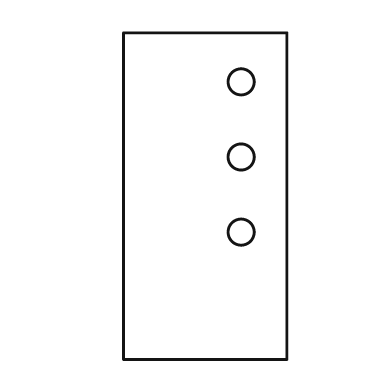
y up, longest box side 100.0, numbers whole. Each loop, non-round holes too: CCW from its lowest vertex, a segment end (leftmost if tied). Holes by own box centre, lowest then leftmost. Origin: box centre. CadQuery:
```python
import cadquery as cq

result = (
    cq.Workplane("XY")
    .moveTo(-25.0, -50.0)
    .lineTo(25.0, -50.0)
    .lineTo(25.0, 50.0)
    .lineTo(-25.0, 50.0)
    .close()
    .moveTo(11.0, -11.0)
    .circle(4.0)
    .moveTo(11.0, 12.0)
    .circle(4.0)
    .moveTo(11.0, 35.0)
    .circle(4.0)
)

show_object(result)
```